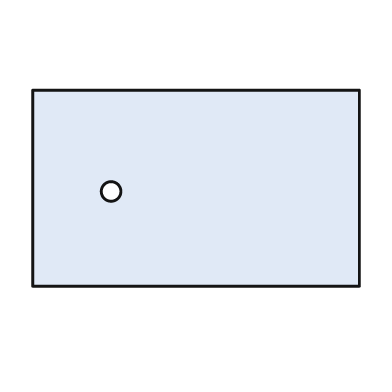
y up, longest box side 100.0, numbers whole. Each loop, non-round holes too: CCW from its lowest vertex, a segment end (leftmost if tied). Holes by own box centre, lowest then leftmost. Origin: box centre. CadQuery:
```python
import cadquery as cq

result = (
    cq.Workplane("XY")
    .moveTo(-50.0, -30.0)
    .lineTo(50.0, -30.0)
    .lineTo(50.0, 30.0)
    .lineTo(-50.0, 30.0)
    .close()
    .moveTo(-26.0, -1.0)
    .circle(3.0)
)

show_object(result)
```